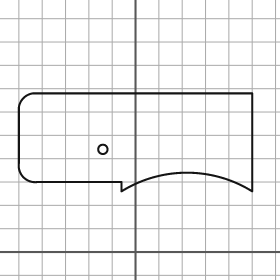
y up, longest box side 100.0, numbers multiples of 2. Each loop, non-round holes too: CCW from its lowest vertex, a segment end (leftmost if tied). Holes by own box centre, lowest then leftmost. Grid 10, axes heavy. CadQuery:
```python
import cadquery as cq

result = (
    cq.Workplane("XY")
    .moveTo(-6.0, 26.0)
    .threePointArc((22.0, 34.0), (50.0, 26.0))
    .lineTo(50.0, 68.0)
    .lineTo(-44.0, 68.0)
    .threePointArc((-48.0, 66.0), (-50.0, 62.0))
    .lineTo(-50.0, 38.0)
    .threePointArc((-48.0, 32.0), (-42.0, 30.0))
    .lineTo(-6.0, 30.0)
    .close()
    .moveTo(-14.0, 44.0)
    .circle(2.0)
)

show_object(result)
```